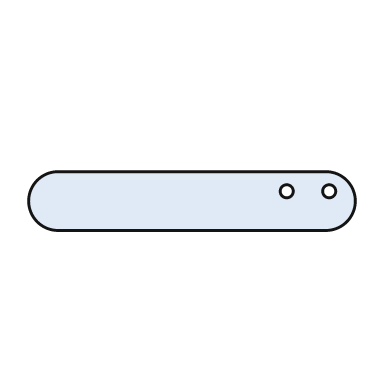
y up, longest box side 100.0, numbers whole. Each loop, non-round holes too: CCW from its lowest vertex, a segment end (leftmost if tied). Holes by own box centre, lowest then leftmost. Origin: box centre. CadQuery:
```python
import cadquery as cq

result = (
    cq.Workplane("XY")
    .moveTo(-41.0, -9.0)
    .lineTo(41.0, -9.0)
    .threePointArc((50.0, 0.0), (41.0, 9.0))
    .lineTo(-41.0, 9.0)
    .threePointArc((-50.0, 0.0), (-41.0, -9.0))
    .close()
    .moveTo(29.0, 3.0)
    .circle(2.0)
    .moveTo(42.0, 3.0)
    .circle(2.0)
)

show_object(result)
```